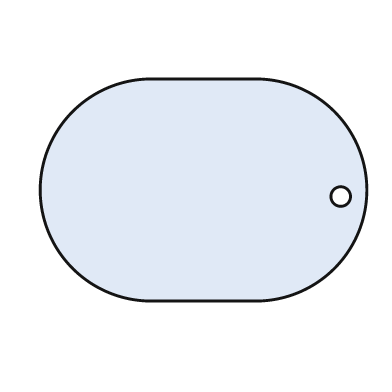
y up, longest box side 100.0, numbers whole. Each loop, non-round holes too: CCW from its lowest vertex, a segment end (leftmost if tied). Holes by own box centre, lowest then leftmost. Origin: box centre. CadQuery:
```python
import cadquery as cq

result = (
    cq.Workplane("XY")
    .moveTo(-16.0, -34.0)
    .lineTo(16.0, -34.0)
    .threePointArc((50.0, 0.0), (16.0, 34.0))
    .lineTo(-16.0, 34.0)
    .threePointArc((-50.0, 0.0), (-16.0, -34.0))
    .close()
    .moveTo(42.0, -2.0)
    .circle(3.0)
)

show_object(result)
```